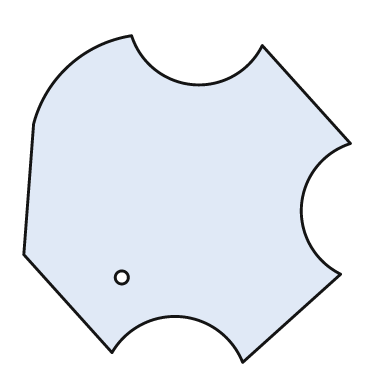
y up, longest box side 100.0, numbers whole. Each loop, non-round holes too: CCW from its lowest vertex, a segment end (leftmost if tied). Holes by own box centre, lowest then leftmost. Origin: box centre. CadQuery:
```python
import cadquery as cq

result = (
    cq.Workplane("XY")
    .moveTo(17.0, -50.0)
    .lineTo(47.0, -23.0)
    .threePointArc((35.0, -2.0), (50.0, 17.0))
    .lineTo(23.0, 47.0)
    .threePointArc((2.0, 35.0), (-17.0, 50.0))
    .threePointArc((-36.0, 41.0), (-47.0, 23.0))
    .lineTo(-50.0, -17.0)
    .lineTo(-23.0, -47.0)
    .threePointArc((-2.0, -36.0), (17.0, -50.0))
    .close()
    .moveTo(-20.0, -24.0)
    .circle(2.0)
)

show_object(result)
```